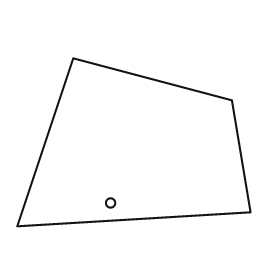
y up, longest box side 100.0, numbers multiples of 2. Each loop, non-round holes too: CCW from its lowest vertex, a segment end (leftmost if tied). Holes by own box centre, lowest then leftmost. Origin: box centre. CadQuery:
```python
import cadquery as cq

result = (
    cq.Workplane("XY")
    .moveTo(-50.0, -36.0)
    .lineTo(50.0, -30.0)
    .lineTo(42.0, 18.0)
    .lineTo(-26.0, 36.0)
    .close()
    .moveTo(-10.0, -26.0)
    .circle(2.0)
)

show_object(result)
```